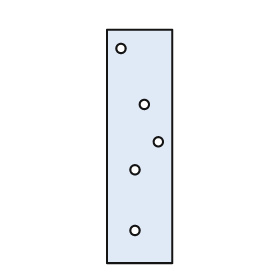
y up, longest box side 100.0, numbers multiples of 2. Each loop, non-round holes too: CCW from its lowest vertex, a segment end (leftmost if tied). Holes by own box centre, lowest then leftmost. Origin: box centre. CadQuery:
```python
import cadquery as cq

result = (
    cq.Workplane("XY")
    .moveTo(-14.0, -50.0)
    .lineTo(14.0, -50.0)
    .lineTo(14.0, 50.0)
    .lineTo(-14.0, 50.0)
    .close()
    .moveTo(-2.0, -36.0)
    .circle(2.0)
    .moveTo(-2.0, -10.0)
    .circle(2.0)
    .moveTo(8.0, 2.0)
    .circle(2.0)
    .moveTo(2.0, 18.0)
    .circle(2.0)
    .moveTo(-8.0, 42.0)
    .circle(2.0)
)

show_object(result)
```